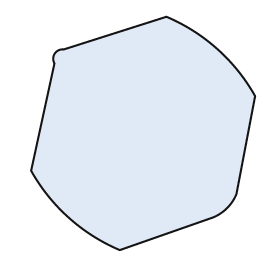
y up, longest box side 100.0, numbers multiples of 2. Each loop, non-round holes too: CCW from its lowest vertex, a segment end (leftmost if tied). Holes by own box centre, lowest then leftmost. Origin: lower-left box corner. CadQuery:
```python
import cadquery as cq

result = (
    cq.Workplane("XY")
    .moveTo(38.0, 0.0)
    .lineTo(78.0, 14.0)
    .threePointArc((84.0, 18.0), (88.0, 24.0))
    .lineTo(96.0, 66.0)
    .threePointArc((80.0, 86.0), (58.0, 100.0))
    .lineTo(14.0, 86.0)
    .threePointArc((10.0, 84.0), (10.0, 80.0))
    .lineTo(0.0, 34.0)
    .threePointArc((16.0, 14.0), (38.0, 0.0))
    .close()
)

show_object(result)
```